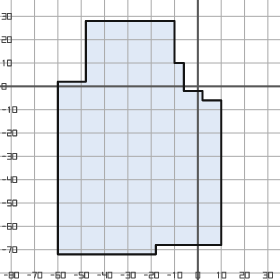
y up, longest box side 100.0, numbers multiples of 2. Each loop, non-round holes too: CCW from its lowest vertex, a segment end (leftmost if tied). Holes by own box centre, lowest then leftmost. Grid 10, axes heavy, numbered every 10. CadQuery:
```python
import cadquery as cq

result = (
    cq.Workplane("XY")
    .moveTo(-60.0, -72.0)
    .lineTo(-18.0, -72.0)
    .lineTo(-18.0, -68.0)
    .lineTo(10.0, -68.0)
    .lineTo(10.0, -6.0)
    .lineTo(2.0, -6.0)
    .lineTo(2.0, -2.0)
    .lineTo(-6.0, -2.0)
    .lineTo(-6.0, 10.0)
    .lineTo(-10.0, 10.0)
    .lineTo(-10.0, 28.0)
    .lineTo(-48.0, 28.0)
    .lineTo(-48.0, 2.0)
    .lineTo(-60.0, 2.0)
    .close()
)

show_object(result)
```